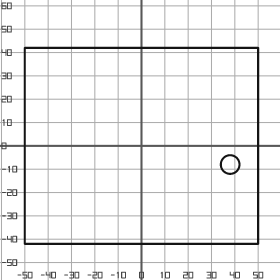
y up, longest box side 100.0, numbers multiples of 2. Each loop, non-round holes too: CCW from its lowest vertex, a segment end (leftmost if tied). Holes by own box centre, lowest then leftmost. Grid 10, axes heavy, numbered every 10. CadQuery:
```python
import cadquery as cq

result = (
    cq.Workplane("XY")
    .moveTo(-50.0, -42.0)
    .lineTo(50.0, -42.0)
    .lineTo(50.0, 42.0)
    .lineTo(-50.0, 42.0)
    .close()
    .moveTo(38.0, -8.0)
    .circle(4.0)
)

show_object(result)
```